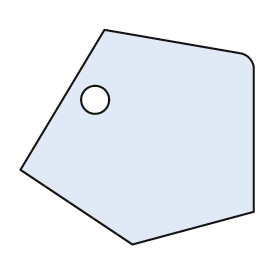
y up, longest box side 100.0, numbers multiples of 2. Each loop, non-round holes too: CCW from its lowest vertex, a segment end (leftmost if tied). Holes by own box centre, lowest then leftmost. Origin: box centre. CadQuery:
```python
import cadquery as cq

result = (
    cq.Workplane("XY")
    .moveTo(-2.0, -46.0)
    .lineTo(50.0, -32.0)
    .lineTo(50.0, 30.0)
    .threePointArc((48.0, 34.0), (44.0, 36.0))
    .lineTo(-14.0, 46.0)
    .lineTo(-50.0, -14.0)
    .close()
    .moveTo(-18.0, 16.0)
    .circle(6.0)
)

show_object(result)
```